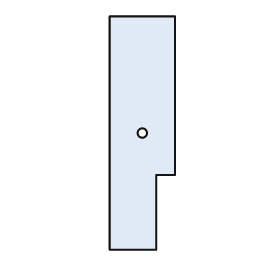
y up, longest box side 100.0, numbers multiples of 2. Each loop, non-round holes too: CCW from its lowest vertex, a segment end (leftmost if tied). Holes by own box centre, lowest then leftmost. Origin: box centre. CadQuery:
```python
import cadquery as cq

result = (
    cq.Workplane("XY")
    .moveTo(-14.0, -50.0)
    .lineTo(6.0, -50.0)
    .lineTo(6.0, -18.0)
    .lineTo(14.0, -18.0)
    .lineTo(14.0, 50.0)
    .lineTo(-14.0, 50.0)
    .close()
    .moveTo(0.0, 0.0)
    .circle(2.0)
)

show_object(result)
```